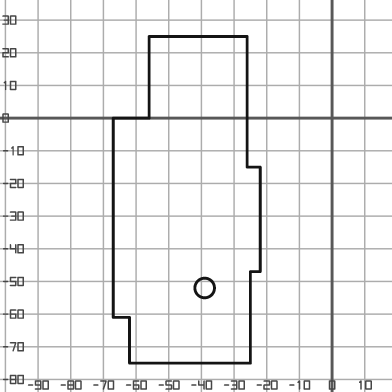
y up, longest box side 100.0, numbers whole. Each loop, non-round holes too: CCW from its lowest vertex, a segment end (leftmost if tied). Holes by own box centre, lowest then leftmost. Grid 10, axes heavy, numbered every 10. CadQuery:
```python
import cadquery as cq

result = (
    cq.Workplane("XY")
    .moveTo(-62.0, -75.0)
    .lineTo(-25.0, -75.0)
    .lineTo(-25.0, -47.0)
    .lineTo(-22.0, -47.0)
    .lineTo(-22.0, -15.0)
    .lineTo(-26.0, -15.0)
    .lineTo(-26.0, 25.0)
    .lineTo(-56.0, 25.0)
    .lineTo(-56.0, 0.0)
    .lineTo(-67.0, 0.0)
    .lineTo(-67.0, -61.0)
    .lineTo(-62.0, -61.0)
    .close()
    .moveTo(-39.0, -52.0)
    .circle(3.0)
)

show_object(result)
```